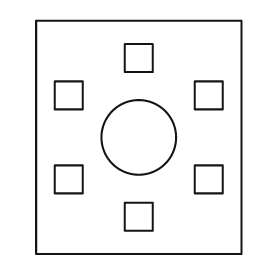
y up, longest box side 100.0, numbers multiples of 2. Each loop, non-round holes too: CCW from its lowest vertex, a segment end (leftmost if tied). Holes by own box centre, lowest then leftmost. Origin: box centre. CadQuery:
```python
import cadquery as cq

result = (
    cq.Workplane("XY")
    .moveTo(-44.0, -50.0)
    .lineTo(44.0, -50.0)
    .lineTo(44.0, 50.0)
    .lineTo(-44.0, 50.0)
    .close()
    .moveTo(-6.0, -40.0)
    .lineTo(6.0, -40.0)
    .lineTo(6.0, -28.0)
    .lineTo(-6.0, -28.0)
    .close()
    .moveTo(-36.0, -24.0)
    .lineTo(-24.0, -24.0)
    .lineTo(-24.0, -12.0)
    .lineTo(-36.0, -12.0)
    .close()
    .moveTo(24.0, -24.0)
    .lineTo(36.0, -24.0)
    .lineTo(36.0, -12.0)
    .lineTo(24.0, -12.0)
    .close()
    .moveTo(0.0, 0.0)
    .circle(16.0)
    .moveTo(-36.0, 12.0)
    .lineTo(-24.0, 12.0)
    .lineTo(-24.0, 24.0)
    .lineTo(-36.0, 24.0)
    .close()
    .moveTo(24.0, 12.0)
    .lineTo(36.0, 12.0)
    .lineTo(36.0, 24.0)
    .lineTo(24.0, 24.0)
    .close()
    .moveTo(-6.0, 28.0)
    .lineTo(6.0, 28.0)
    .lineTo(6.0, 40.0)
    .lineTo(-6.0, 40.0)
    .close()
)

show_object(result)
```